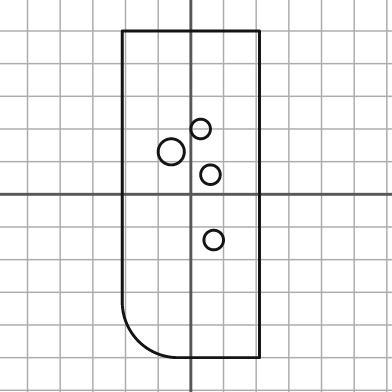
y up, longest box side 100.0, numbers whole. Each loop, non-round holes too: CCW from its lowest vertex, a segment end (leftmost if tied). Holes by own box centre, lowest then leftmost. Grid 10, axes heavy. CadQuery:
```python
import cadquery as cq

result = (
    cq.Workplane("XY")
    .moveTo(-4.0, -50.0)
    .lineTo(21.0, -50.0)
    .lineTo(21.0, 50.0)
    .lineTo(-21.0, 50.0)
    .lineTo(-21.0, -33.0)
    .threePointArc((-16.0, -45.0), (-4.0, -50.0))
    .close()
    .moveTo(7.0, -14.0)
    .circle(3.0)
    .moveTo(6.0, 6.0)
    .circle(3.0)
    .moveTo(-6.0, 13.0)
    .circle(4.0)
    .moveTo(3.0, 20.0)
    .circle(3.0)
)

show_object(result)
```